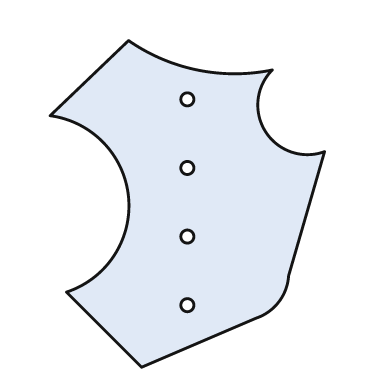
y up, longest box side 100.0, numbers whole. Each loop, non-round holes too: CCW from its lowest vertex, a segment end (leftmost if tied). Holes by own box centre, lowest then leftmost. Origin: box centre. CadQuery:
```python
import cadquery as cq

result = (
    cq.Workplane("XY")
    .moveTo(-14.0, -50.0)
    .lineTo(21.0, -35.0)
    .threePointArc((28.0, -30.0), (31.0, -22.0))
    .lineTo(42.0, 16.0)
    .threePointArc((24.0, 22.0), (26.0, 41.0))
    .threePointArc((3.0, 41.0), (-18.0, 50.0))
    .lineTo(-42.0, 27.0)
    .threePointArc((-18.0, 2.0), (-37.0, -27.0))
    .close()
    .moveTo(0.0, -31.0)
    .circle(2.0)
    .moveTo(0.0, -10.0)
    .circle(2.0)
    .moveTo(0.0, 11.0)
    .circle(2.0)
    .moveTo(0.0, 32.0)
    .circle(2.0)
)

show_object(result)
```